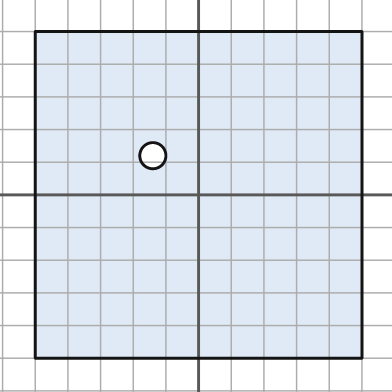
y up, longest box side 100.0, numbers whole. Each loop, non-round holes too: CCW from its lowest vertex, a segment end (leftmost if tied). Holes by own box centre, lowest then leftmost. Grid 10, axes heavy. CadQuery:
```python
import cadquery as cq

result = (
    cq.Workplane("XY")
    .moveTo(-50.0, -50.0)
    .lineTo(50.0, -50.0)
    .lineTo(50.0, 50.0)
    .lineTo(-50.0, 50.0)
    .close()
    .moveTo(-14.0, 12.0)
    .circle(4.0)
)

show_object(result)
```